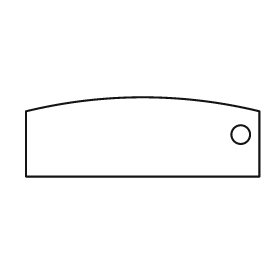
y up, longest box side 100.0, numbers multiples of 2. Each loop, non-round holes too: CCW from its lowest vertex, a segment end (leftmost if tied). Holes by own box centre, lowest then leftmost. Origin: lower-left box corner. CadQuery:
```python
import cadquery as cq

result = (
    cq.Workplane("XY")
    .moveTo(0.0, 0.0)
    .lineTo(100.0, 0.0)
    .lineTo(100.0, 28.0)
    .threePointArc((50.0, 34.0), (0.0, 28.0))
    .close()
    .moveTo(92.0, 18.0)
    .circle(4.0)
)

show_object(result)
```